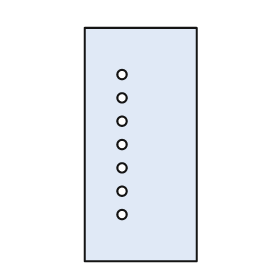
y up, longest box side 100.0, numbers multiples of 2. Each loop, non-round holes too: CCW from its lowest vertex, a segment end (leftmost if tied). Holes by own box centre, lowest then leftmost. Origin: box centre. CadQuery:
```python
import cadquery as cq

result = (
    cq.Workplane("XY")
    .moveTo(-24.0, -50.0)
    .lineTo(24.0, -50.0)
    .lineTo(24.0, 50.0)
    .lineTo(-24.0, 50.0)
    .close()
    .moveTo(-8.0, -30.0)
    .circle(2.0)
    .moveTo(-8.0, -20.0)
    .circle(2.0)
    .moveTo(-8.0, -10.0)
    .circle(2.0)
    .moveTo(-8.0, 0.0)
    .circle(2.0)
    .moveTo(-8.0, 10.0)
    .circle(2.0)
    .moveTo(-8.0, 20.0)
    .circle(2.0)
    .moveTo(-8.0, 30.0)
    .circle(2.0)
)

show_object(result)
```